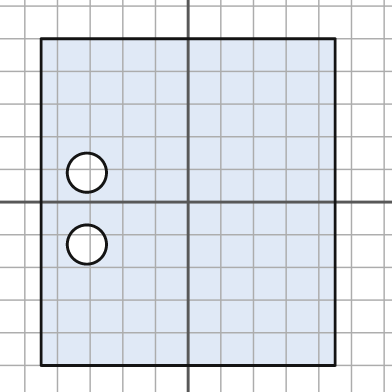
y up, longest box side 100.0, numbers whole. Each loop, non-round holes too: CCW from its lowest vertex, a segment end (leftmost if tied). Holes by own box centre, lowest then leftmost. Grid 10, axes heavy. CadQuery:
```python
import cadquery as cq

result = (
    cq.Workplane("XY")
    .moveTo(-45.0, -50.0)
    .lineTo(45.0, -50.0)
    .lineTo(45.0, 50.0)
    .lineTo(-45.0, 50.0)
    .close()
    .moveTo(-31.0, -13.0)
    .circle(6.0)
    .moveTo(-31.0, 9.0)
    .circle(6.0)
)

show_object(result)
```